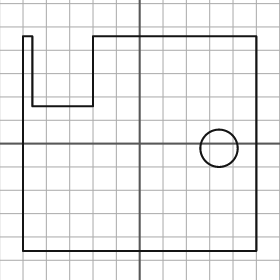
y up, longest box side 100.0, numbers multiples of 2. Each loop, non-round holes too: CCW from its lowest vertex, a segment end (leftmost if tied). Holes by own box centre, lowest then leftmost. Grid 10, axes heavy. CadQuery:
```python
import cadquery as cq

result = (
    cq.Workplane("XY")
    .moveTo(-50.0, -46.0)
    .lineTo(50.0, -46.0)
    .lineTo(50.0, 46.0)
    .lineTo(-20.0, 46.0)
    .lineTo(-20.0, 16.0)
    .lineTo(-46.0, 16.0)
    .lineTo(-46.0, 46.0)
    .lineTo(-50.0, 46.0)
    .close()
    .moveTo(34.0, -2.0)
    .circle(8.0)
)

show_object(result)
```